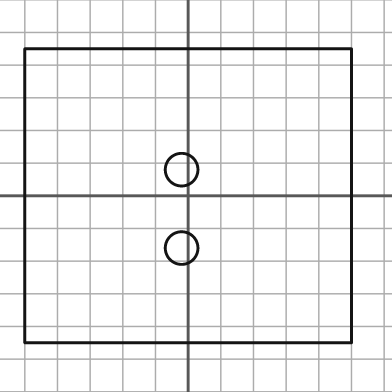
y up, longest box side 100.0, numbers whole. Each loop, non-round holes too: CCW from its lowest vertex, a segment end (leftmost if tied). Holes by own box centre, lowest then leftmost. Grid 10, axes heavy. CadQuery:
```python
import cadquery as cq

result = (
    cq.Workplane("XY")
    .moveTo(-50.0, -45.0)
    .lineTo(50.0, -45.0)
    .lineTo(50.0, 45.0)
    .lineTo(-50.0, 45.0)
    .close()
    .moveTo(-2.0, -16.0)
    .circle(5.0)
    .moveTo(-2.0, 8.0)
    .circle(5.0)
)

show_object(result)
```